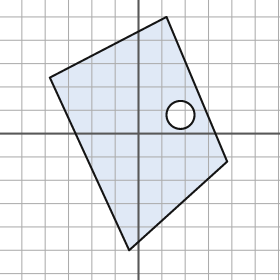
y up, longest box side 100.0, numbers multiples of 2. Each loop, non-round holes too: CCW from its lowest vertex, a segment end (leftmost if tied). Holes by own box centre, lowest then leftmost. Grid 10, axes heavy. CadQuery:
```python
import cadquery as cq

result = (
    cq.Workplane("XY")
    .moveTo(-4.0, -50.0)
    .lineTo(38.0, -12.0)
    .lineTo(12.0, 50.0)
    .lineTo(-38.0, 24.0)
    .close()
    .moveTo(18.0, 8.0)
    .circle(6.0)
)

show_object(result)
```